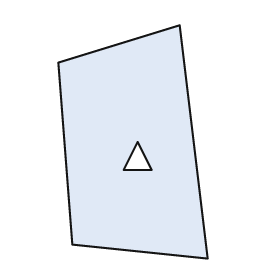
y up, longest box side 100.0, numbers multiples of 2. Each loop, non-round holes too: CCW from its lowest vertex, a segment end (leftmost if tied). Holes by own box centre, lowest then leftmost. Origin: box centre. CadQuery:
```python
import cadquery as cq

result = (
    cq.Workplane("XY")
    .moveTo(32.0, -50.0)
    .lineTo(20.0, 50.0)
    .lineTo(-32.0, 34.0)
    .lineTo(-26.0, -44.0)
    .close()
    .moveTo(-4.0, -12.0)
    .lineTo(8.0, -12.0)
    .lineTo(2.0, 0.0)
    .close()
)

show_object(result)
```